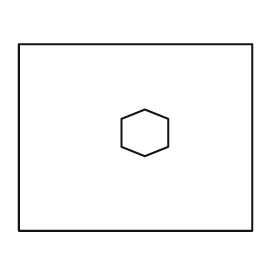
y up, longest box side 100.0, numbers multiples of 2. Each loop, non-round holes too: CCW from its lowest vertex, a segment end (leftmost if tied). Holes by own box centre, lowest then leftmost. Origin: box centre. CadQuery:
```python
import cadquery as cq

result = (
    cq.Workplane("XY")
    .moveTo(-50.0, -40.0)
    .lineTo(50.0, -40.0)
    .lineTo(50.0, 40.0)
    .lineTo(-50.0, 40.0)
    .close()
    .moveTo(4.0, -8.0)
    .lineTo(14.0, -4.0)
    .lineTo(14.0, 8.0)
    .lineTo(4.0, 12.0)
    .lineTo(-6.0, 8.0)
    .lineTo(-6.0, -4.0)
    .close()
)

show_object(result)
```